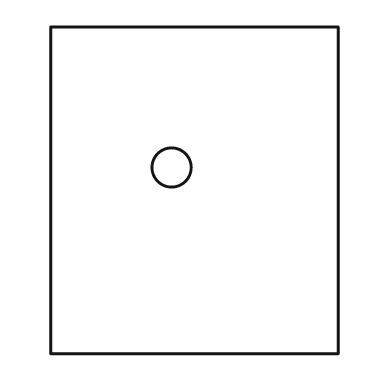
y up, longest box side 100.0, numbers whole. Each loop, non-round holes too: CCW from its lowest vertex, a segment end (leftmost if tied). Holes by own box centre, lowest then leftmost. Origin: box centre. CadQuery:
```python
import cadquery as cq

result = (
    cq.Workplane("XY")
    .moveTo(-44.0, -50.0)
    .lineTo(44.0, -50.0)
    .lineTo(44.0, 50.0)
    .lineTo(-44.0, 50.0)
    .close()
    .moveTo(-7.0, 7.0)
    .circle(6.0)
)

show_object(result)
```